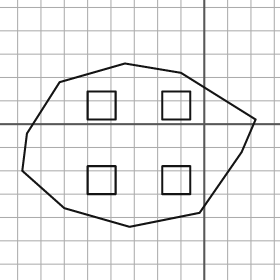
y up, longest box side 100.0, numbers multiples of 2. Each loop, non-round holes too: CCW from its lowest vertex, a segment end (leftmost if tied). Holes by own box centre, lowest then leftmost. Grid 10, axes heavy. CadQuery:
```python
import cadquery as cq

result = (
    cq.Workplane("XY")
    .moveTo(-32.0, -44.0)
    .lineTo(-2.0, -38.0)
    .lineTo(16.0, -12.0)
    .lineTo(22.0, 2.0)
    .lineTo(-10.0, 22.0)
    .lineTo(-34.0, 26.0)
    .lineTo(-62.0, 18.0)
    .lineTo(-76.0, -4.0)
    .lineTo(-78.0, -20.0)
    .lineTo(-60.0, -36.0)
    .close()
    .moveTo(-50.0, -30.0)
    .lineTo(-38.0, -30.0)
    .lineTo(-38.0, -18.0)
    .lineTo(-50.0, -18.0)
    .close()
    .moveTo(-18.0, -30.0)
    .lineTo(-6.0, -30.0)
    .lineTo(-6.0, -18.0)
    .lineTo(-18.0, -18.0)
    .close()
    .moveTo(-50.0, 2.0)
    .lineTo(-38.0, 2.0)
    .lineTo(-38.0, 14.0)
    .lineTo(-50.0, 14.0)
    .close()
    .moveTo(-18.0, 2.0)
    .lineTo(-6.0, 2.0)
    .lineTo(-6.0, 14.0)
    .lineTo(-18.0, 14.0)
    .close()
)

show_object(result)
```